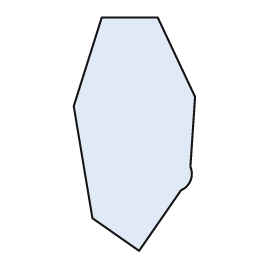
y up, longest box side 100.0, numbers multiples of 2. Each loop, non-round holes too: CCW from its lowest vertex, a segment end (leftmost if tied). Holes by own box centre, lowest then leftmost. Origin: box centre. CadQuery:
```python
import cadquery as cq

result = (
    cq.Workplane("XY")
    .moveTo(2.0, -50.0)
    .lineTo(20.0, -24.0)
    .threePointArc((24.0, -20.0), (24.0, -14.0))
    .lineTo(26.0, 16.0)
    .lineTo(10.0, 50.0)
    .lineTo(-14.0, 50.0)
    .lineTo(-26.0, 12.0)
    .lineTo(-18.0, -36.0)
    .close()
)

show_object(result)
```